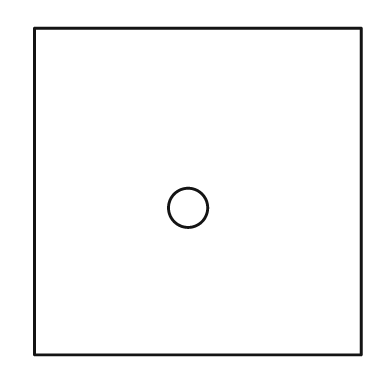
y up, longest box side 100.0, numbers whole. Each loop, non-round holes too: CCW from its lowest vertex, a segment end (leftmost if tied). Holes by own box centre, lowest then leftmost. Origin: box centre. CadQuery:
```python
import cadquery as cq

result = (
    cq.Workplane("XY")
    .moveTo(-50.0, -50.0)
    .lineTo(50.0, -50.0)
    .lineTo(50.0, 50.0)
    .lineTo(-50.0, 50.0)
    .close()
    .moveTo(-3.0, -5.0)
    .circle(6.0)
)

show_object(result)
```